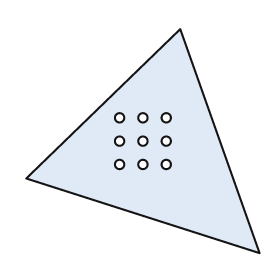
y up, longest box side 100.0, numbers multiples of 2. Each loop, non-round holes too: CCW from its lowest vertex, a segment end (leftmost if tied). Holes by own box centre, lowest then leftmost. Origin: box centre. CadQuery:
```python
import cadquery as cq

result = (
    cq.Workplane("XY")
    .moveTo(50.0, -48.0)
    .lineTo(16.0, 48.0)
    .lineTo(-50.0, -16.0)
    .close()
    .moveTo(-10.0, -10.0)
    .circle(2.0)
    .moveTo(0.0, -10.0)
    .circle(2.0)
    .moveTo(10.0, -10.0)
    .circle(2.0)
    .moveTo(-10.0, 0.0)
    .circle(2.0)
    .moveTo(0.0, 0.0)
    .circle(2.0)
    .moveTo(10.0, 0.0)
    .circle(2.0)
    .moveTo(-10.0, 10.0)
    .circle(2.0)
    .moveTo(0.0, 10.0)
    .circle(2.0)
    .moveTo(10.0, 10.0)
    .circle(2.0)
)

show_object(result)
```